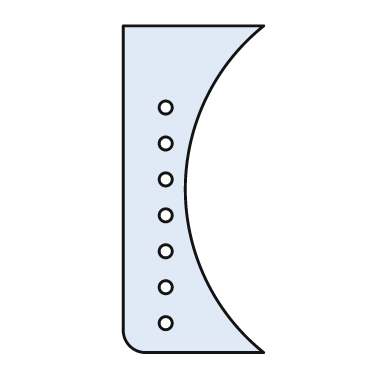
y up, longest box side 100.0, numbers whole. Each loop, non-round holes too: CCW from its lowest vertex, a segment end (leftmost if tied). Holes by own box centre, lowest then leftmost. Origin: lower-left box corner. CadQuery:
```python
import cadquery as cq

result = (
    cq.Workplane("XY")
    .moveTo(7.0, 0.0)
    .lineTo(43.0, 0.0)
    .threePointArc((19.0, 50.0), (43.0, 100.0))
    .lineTo(0.0, 100.0)
    .lineTo(0.0, 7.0)
    .threePointArc((2.0, 2.0), (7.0, 0.0))
    .close()
    .moveTo(13.0, 9.0)
    .circle(2.0)
    .moveTo(13.0, 20.0)
    .circle(2.0)
    .moveTo(13.0, 31.0)
    .circle(2.0)
    .moveTo(13.0, 42.0)
    .circle(2.0)
    .moveTo(13.0, 53.0)
    .circle(2.0)
    .moveTo(13.0, 64.0)
    .circle(2.0)
    .moveTo(13.0, 75.0)
    .circle(2.0)
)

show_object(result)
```